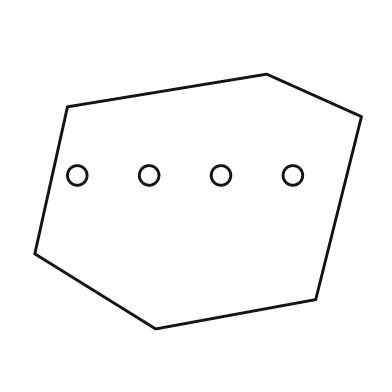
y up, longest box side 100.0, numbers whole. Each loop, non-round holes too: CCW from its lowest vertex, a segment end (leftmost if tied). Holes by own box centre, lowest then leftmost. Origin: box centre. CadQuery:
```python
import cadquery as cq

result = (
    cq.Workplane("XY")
    .moveTo(-13.0, -39.0)
    .lineTo(36.0, -30.0)
    .lineTo(50.0, 26.0)
    .lineTo(21.0, 39.0)
    .lineTo(-40.0, 29.0)
    .lineTo(-50.0, -16.0)
    .close()
    .moveTo(-37.0, 8.0)
    .circle(3.0)
    .moveTo(-15.0, 8.0)
    .circle(3.0)
    .moveTo(7.0, 8.0)
    .circle(3.0)
    .moveTo(29.0, 8.0)
    .circle(3.0)
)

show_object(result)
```